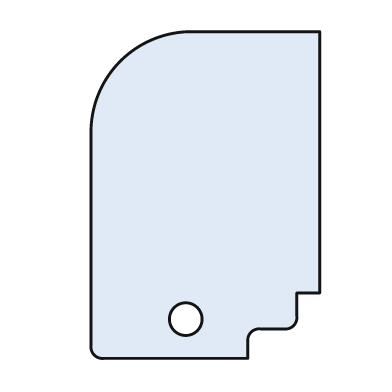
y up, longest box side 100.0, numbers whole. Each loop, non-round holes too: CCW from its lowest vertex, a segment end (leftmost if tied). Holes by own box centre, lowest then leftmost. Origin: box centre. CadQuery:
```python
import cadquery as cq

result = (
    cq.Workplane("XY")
    .moveTo(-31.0, -50.0)
    .lineTo(13.0, -50.0)
    .lineTo(13.0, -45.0)
    .threePointArc((14.0, -42.0), (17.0, -41.0))
    .lineTo(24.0, -41.0)
    .threePointArc((27.0, -40.0), (28.0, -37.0))
    .lineTo(28.0, -30.0)
    .lineTo(35.0, -30.0)
    .lineTo(35.0, 50.0)
    .lineTo(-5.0, 50.0)
    .threePointArc((-26.0, 41.0), (-35.0, 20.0))
    .lineTo(-35.0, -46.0)
    .threePointArc((-34.0, -49.0), (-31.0, -50.0))
    .close()
    .moveTo(-6.0, -38.0)
    .circle(5.0)
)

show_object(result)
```